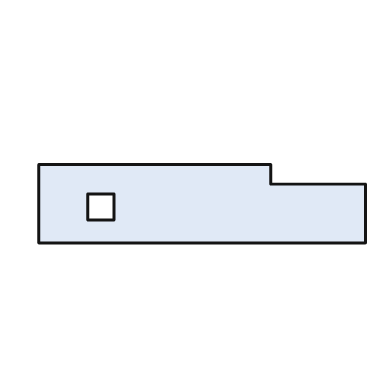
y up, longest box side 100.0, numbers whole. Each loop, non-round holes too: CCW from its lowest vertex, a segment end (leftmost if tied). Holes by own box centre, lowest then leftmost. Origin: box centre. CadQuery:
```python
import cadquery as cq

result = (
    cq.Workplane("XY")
    .moveTo(-50.0, -12.0)
    .lineTo(50.0, -12.0)
    .lineTo(50.0, 6.0)
    .lineTo(21.0, 6.0)
    .lineTo(21.0, 12.0)
    .lineTo(-50.0, 12.0)
    .close()
    .moveTo(-35.0, -5.0)
    .lineTo(-27.0, -5.0)
    .lineTo(-27.0, 3.0)
    .lineTo(-35.0, 3.0)
    .close()
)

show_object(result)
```